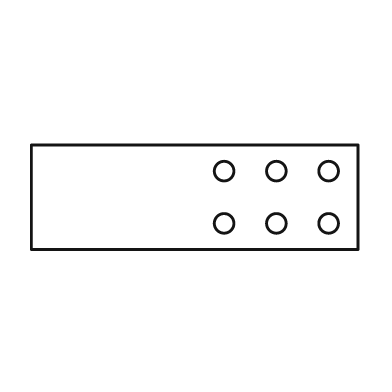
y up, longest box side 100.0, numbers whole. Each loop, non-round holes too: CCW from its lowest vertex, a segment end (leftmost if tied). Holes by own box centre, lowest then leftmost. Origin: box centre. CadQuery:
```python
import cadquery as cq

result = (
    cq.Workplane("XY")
    .moveTo(-50.0, -16.0)
    .lineTo(50.0, -16.0)
    .lineTo(50.0, 16.0)
    .lineTo(-50.0, 16.0)
    .close()
    .moveTo(9.0, -8.0)
    .circle(3.0)
    .moveTo(25.0, -8.0)
    .circle(3.0)
    .moveTo(41.0, -8.0)
    .circle(3.0)
    .moveTo(9.0, 8.0)
    .circle(3.0)
    .moveTo(25.0, 8.0)
    .circle(3.0)
    .moveTo(41.0, 8.0)
    .circle(3.0)
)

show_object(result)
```